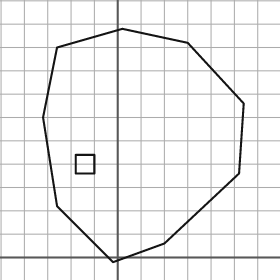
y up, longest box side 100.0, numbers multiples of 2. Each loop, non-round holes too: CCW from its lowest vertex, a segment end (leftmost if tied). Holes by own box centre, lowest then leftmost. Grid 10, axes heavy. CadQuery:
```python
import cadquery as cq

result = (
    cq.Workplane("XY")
    .moveTo(-2.0, -2.0)
    .lineTo(20.0, 6.0)
    .lineTo(52.0, 36.0)
    .lineTo(54.0, 66.0)
    .lineTo(30.0, 92.0)
    .lineTo(2.0, 98.0)
    .lineTo(-26.0, 90.0)
    .lineTo(-32.0, 60.0)
    .lineTo(-26.0, 22.0)
    .close()
    .moveTo(-18.0, 36.0)
    .lineTo(-10.0, 36.0)
    .lineTo(-10.0, 44.0)
    .lineTo(-18.0, 44.0)
    .close()
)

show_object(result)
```